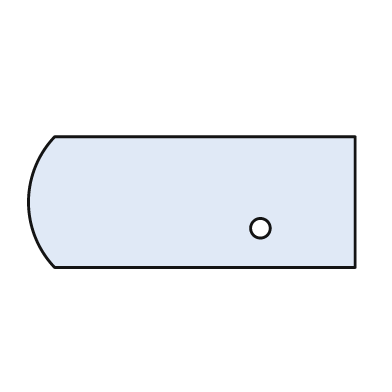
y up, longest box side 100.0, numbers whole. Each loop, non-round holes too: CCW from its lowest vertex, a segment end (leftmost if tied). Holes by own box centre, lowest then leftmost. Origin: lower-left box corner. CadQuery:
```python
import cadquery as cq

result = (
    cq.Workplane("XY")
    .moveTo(8.0, 0.0)
    .lineTo(100.0, 0.0)
    .lineTo(100.0, 40.0)
    .lineTo(8.0, 40.0)
    .threePointArc((0.0, 20.0), (8.0, 0.0))
    .close()
    .moveTo(71.0, 12.0)
    .circle(3.0)
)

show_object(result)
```